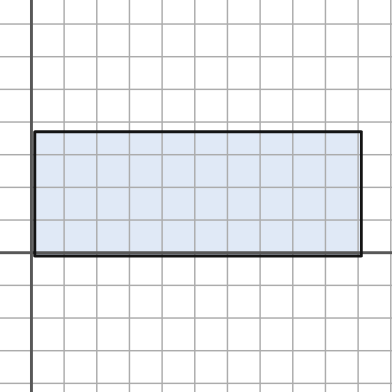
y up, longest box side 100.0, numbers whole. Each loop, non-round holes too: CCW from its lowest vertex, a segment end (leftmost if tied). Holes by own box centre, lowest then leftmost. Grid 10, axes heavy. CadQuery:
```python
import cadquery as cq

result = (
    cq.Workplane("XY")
    .moveTo(1.0, -1.0)
    .lineTo(101.0, -1.0)
    .lineTo(101.0, 37.0)
    .lineTo(1.0, 37.0)
    .close()
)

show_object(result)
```